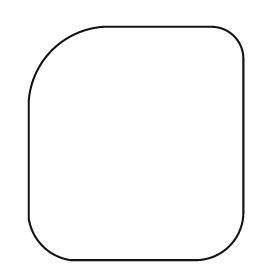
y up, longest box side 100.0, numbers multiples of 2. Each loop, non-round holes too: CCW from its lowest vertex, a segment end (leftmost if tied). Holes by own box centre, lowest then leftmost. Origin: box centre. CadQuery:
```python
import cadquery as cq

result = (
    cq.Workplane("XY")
    .moveTo(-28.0, -50.0)
    .lineTo(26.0, -50.0)
    .threePointArc((40.0, -44.0), (46.0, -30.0))
    .lineTo(46.0, 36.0)
    .threePointArc((42.0, 46.0), (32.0, 50.0))
    .lineTo(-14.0, 50.0)
    .threePointArc((-36.0, 40.0), (-46.0, 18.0))
    .lineTo(-46.0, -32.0)
    .threePointArc((-40.0, -44.0), (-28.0, -50.0))
    .close()
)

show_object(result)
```